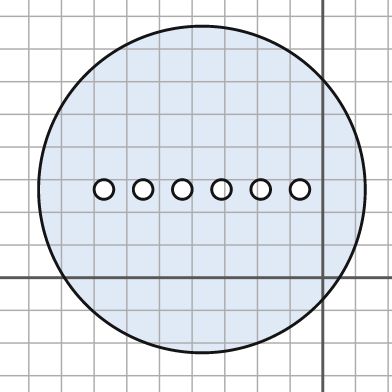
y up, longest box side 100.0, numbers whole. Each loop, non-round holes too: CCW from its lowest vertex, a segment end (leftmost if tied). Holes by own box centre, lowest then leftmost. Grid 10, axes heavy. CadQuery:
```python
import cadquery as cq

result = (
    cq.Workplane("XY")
    .moveTo(-37.0, 27.0)
    .circle(50.0)
    .moveTo(-67.0, 27.0)
    .circle(3.0)
    .moveTo(-55.0, 27.0)
    .circle(3.0)
    .moveTo(-43.0, 27.0)
    .circle(3.0)
    .moveTo(-31.0, 27.0)
    .circle(3.0)
    .moveTo(-19.0, 27.0)
    .circle(3.0)
    .moveTo(-7.0, 27.0)
    .circle(3.0)
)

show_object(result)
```